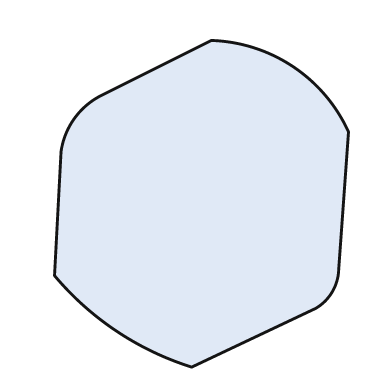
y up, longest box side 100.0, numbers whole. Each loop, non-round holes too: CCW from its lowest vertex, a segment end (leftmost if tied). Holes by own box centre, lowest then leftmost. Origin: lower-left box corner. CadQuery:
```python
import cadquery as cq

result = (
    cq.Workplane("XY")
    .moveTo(42.0, 0.0)
    .lineTo(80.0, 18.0)
    .threePointArc((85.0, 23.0), (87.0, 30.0))
    .lineTo(90.0, 72.0)
    .threePointArc((73.0, 92.0), (48.0, 100.0))
    .lineTo(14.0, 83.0)
    .threePointArc((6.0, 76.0), (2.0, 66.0))
    .lineTo(0.0, 28.0)
    .threePointArc((19.0, 11.0), (42.0, 0.0))
    .close()
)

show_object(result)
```